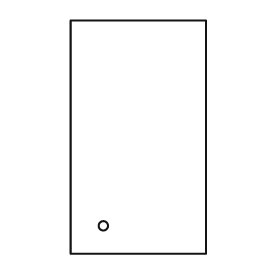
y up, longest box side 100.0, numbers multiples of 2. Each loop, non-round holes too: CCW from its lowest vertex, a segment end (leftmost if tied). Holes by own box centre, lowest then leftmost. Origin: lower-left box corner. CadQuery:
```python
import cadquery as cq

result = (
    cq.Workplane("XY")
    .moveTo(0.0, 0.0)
    .lineTo(58.0, 0.0)
    .lineTo(58.0, 100.0)
    .lineTo(0.0, 100.0)
    .close()
    .moveTo(14.0, 12.0)
    .circle(2.0)
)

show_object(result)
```